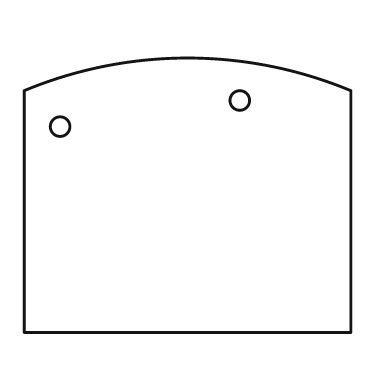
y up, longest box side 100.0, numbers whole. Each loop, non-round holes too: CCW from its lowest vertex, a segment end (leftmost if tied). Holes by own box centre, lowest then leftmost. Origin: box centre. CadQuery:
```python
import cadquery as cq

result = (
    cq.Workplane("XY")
    .moveTo(-50.0, -42.0)
    .lineTo(50.0, -42.0)
    .lineTo(50.0, 32.0)
    .threePointArc((0.0, 42.0), (-50.0, 32.0))
    .close()
    .moveTo(-39.0, 21.0)
    .circle(3.0)
    .moveTo(16.0, 29.0)
    .circle(3.0)
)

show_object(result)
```